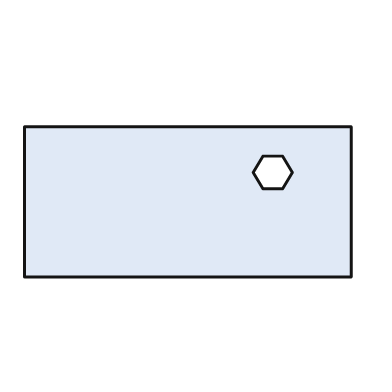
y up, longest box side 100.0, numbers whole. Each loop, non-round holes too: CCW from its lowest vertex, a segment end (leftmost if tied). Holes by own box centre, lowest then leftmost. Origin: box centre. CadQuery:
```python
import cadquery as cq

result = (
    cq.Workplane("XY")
    .moveTo(-50.0, -23.0)
    .lineTo(50.0, -23.0)
    .lineTo(50.0, 23.0)
    .lineTo(-50.0, 23.0)
    .close()
    .moveTo(23.0, 4.0)
    .lineTo(29.0, 4.0)
    .lineTo(32.0, 9.0)
    .lineTo(29.0, 14.0)
    .lineTo(23.0, 14.0)
    .lineTo(20.0, 9.0)
    .close()
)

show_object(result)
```